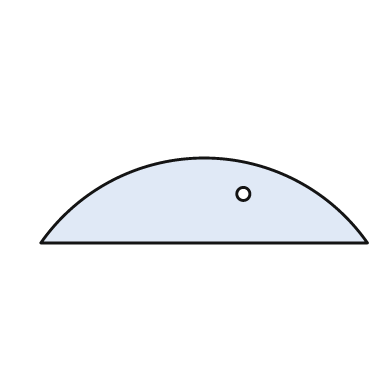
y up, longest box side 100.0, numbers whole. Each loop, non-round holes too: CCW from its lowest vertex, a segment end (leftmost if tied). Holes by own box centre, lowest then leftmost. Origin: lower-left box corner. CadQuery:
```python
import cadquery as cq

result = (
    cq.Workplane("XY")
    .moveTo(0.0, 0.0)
    .lineTo(100.0, 0.0)
    .threePointArc((50.0, 26.0), (0.0, 0.0))
    .close()
    .moveTo(62.0, 15.0)
    .circle(2.0)
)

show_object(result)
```